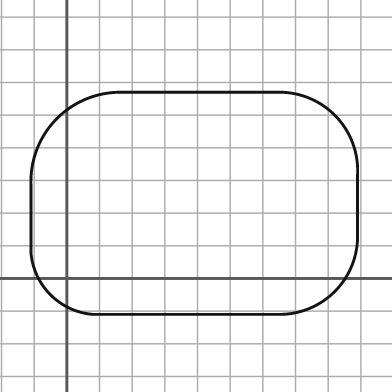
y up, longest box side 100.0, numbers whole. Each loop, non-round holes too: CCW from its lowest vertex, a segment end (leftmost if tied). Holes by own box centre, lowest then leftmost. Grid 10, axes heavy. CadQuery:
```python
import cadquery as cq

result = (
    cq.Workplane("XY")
    .moveTo(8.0, -11.0)
    .lineTo(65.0, -11.0)
    .threePointArc((82.0, -4.0), (89.0, 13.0))
    .lineTo(89.0, 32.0)
    .threePointArc((82.0, 50.0), (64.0, 57.0))
    .lineTo(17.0, 57.0)
    .threePointArc((-3.0, 49.0), (-11.0, 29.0))
    .lineTo(-11.0, 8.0)
    .threePointArc((-5.0, -5.0), (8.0, -11.0))
    .close()
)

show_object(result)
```